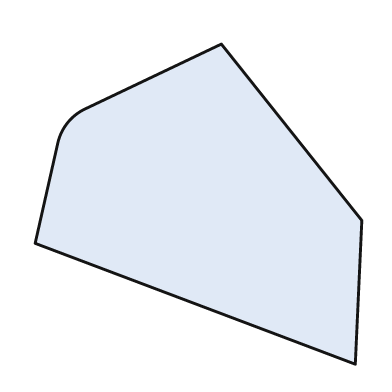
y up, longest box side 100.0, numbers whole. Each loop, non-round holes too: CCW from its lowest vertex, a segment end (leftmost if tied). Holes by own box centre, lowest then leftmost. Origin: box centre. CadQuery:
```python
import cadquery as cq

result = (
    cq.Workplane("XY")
    .moveTo(48.0, -49.0)
    .lineTo(50.0, -5.0)
    .lineTo(7.0, 49.0)
    .lineTo(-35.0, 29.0)
    .threePointArc((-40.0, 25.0), (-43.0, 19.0))
    .lineTo(-50.0, -12.0)
    .close()
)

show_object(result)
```